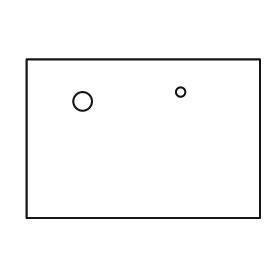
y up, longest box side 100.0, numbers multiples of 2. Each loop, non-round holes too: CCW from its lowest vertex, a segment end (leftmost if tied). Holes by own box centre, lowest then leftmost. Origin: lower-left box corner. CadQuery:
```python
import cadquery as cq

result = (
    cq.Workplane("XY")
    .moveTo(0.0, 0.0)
    .lineTo(100.0, 0.0)
    .lineTo(100.0, 68.0)
    .lineTo(0.0, 68.0)
    .close()
    .moveTo(24.0, 50.0)
    .circle(4.0)
    .moveTo(66.0, 54.0)
    .circle(2.0)
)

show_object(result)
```